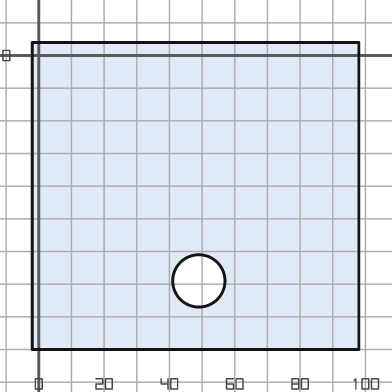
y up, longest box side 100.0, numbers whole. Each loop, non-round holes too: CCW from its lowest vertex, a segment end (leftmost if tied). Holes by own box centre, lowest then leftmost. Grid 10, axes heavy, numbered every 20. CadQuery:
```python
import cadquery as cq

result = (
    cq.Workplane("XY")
    .moveTo(-2.0, -90.0)
    .lineTo(98.0, -90.0)
    .lineTo(98.0, 4.0)
    .lineTo(-2.0, 4.0)
    .close()
    .moveTo(49.0, -69.0)
    .circle(8.0)
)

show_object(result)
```